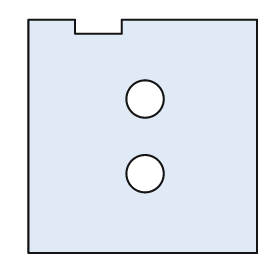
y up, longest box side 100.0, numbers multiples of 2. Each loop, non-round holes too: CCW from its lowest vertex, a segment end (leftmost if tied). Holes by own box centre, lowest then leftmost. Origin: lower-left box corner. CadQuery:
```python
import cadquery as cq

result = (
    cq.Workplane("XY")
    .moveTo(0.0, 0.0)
    .lineTo(98.0, 0.0)
    .lineTo(98.0, 100.0)
    .lineTo(40.0, 100.0)
    .lineTo(40.0, 94.0)
    .lineTo(20.0, 94.0)
    .lineTo(20.0, 100.0)
    .lineTo(0.0, 100.0)
    .close()
    .moveTo(50.0, 34.0)
    .circle(8.0)
    .moveTo(50.0, 66.0)
    .circle(8.0)
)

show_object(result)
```